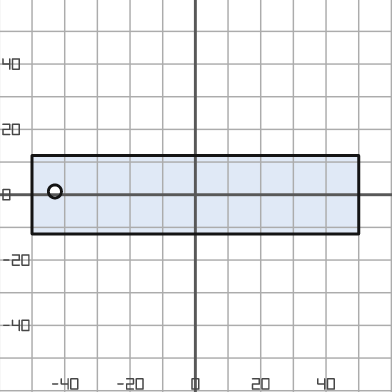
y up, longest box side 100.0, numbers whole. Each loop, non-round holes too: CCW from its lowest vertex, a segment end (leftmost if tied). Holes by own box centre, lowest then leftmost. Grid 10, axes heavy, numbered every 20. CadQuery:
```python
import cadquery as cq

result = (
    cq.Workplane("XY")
    .moveTo(-50.0, -12.0)
    .lineTo(50.0, -12.0)
    .lineTo(50.0, 12.0)
    .lineTo(-50.0, 12.0)
    .close()
    .moveTo(-43.0, 1.0)
    .circle(2.0)
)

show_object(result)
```